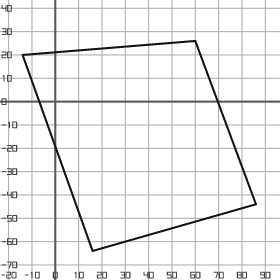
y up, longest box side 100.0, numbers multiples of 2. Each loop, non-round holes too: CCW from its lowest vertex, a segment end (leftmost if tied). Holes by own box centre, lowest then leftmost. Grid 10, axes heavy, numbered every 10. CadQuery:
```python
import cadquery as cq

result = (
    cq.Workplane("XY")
    .moveTo(16.0, -64.0)
    .lineTo(86.0, -44.0)
    .lineTo(60.0, 26.0)
    .lineTo(-14.0, 20.0)
    .close()
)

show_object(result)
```